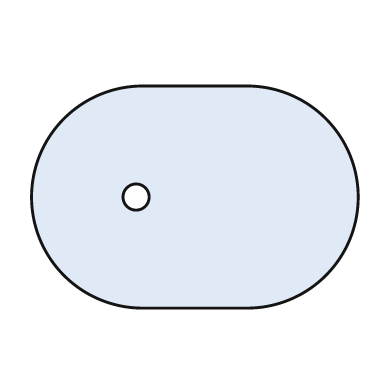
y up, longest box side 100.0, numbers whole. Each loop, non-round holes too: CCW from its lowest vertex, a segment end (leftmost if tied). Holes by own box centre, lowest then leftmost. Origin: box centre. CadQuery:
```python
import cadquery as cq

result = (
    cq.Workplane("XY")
    .moveTo(-16.0, -34.0)
    .lineTo(16.0, -34.0)
    .threePointArc((50.0, 0.0), (16.0, 34.0))
    .lineTo(-16.0, 34.0)
    .threePointArc((-50.0, 0.0), (-16.0, -34.0))
    .close()
    .moveTo(-18.0, 0.0)
    .circle(4.0)
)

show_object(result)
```